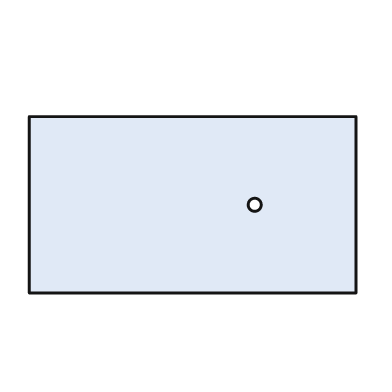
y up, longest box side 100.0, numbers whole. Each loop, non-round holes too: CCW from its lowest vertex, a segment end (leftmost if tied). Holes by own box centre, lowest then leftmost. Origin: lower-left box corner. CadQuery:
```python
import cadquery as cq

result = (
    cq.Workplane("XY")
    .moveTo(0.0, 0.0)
    .lineTo(100.0, 0.0)
    .lineTo(100.0, 54.0)
    .lineTo(0.0, 54.0)
    .close()
    .moveTo(69.0, 27.0)
    .circle(2.0)
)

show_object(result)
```